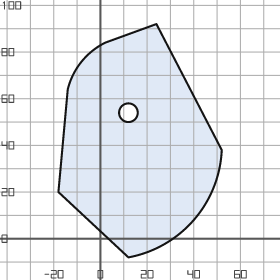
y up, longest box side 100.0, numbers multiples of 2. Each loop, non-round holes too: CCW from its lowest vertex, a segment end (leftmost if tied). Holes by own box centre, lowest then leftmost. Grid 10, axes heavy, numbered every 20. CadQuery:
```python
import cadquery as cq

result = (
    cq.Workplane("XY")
    .moveTo(12.0, -8.0)
    .threePointArc((40.0, 8.0), (52.0, 38.0))
    .lineTo(24.0, 92.0)
    .lineTo(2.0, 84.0)
    .threePointArc((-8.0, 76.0), (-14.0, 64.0))
    .lineTo(-18.0, 20.0)
    .close()
    .moveTo(12.0, 54.0)
    .circle(4.0)
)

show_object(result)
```